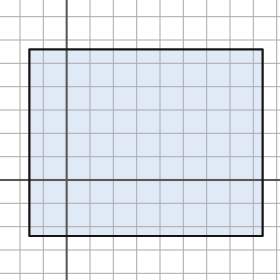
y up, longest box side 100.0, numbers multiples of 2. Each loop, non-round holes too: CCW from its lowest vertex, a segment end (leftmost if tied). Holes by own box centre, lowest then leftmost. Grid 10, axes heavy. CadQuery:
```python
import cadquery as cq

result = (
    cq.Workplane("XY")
    .moveTo(-16.0, -24.0)
    .lineTo(84.0, -24.0)
    .lineTo(84.0, 56.0)
    .lineTo(-16.0, 56.0)
    .close()
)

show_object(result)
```